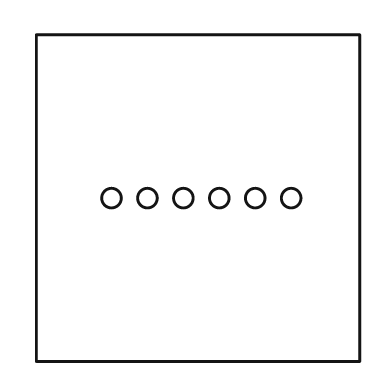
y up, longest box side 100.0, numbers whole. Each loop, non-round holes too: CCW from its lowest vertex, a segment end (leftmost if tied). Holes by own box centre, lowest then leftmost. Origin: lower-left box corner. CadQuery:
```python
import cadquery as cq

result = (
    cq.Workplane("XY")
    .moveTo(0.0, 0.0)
    .lineTo(99.0, 0.0)
    .lineTo(99.0, 100.0)
    .lineTo(0.0, 100.0)
    .close()
    .moveTo(23.0, 50.0)
    .circle(3.0)
    .moveTo(34.0, 50.0)
    .circle(3.0)
    .moveTo(45.0, 50.0)
    .circle(3.0)
    .moveTo(56.0, 50.0)
    .circle(3.0)
    .moveTo(67.0, 50.0)
    .circle(3.0)
    .moveTo(78.0, 50.0)
    .circle(3.0)
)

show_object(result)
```